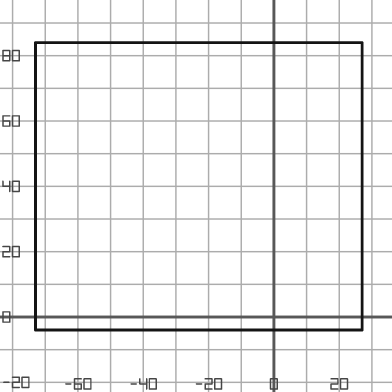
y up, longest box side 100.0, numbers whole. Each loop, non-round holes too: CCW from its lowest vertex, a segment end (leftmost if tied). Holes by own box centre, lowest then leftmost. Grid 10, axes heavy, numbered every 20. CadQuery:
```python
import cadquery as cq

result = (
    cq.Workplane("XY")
    .moveTo(-73.0, -4.0)
    .lineTo(27.0, -4.0)
    .lineTo(27.0, 84.0)
    .lineTo(-73.0, 84.0)
    .close()
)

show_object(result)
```